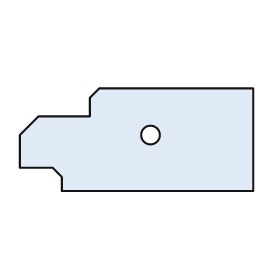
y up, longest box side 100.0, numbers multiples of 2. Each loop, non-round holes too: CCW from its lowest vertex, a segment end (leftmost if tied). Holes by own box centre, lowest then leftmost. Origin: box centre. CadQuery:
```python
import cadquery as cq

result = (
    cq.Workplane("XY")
    .moveTo(-32.0, -22.0)
    .lineTo(50.0, -22.0)
    .lineTo(50.0, 22.0)
    .lineTo(-16.0, 22.0)
    .lineTo(-20.0, 18.0)
    .lineTo(-20.0, 10.0)
    .lineTo(-42.0, 10.0)
    .lineTo(-50.0, 2.0)
    .lineTo(-50.0, -12.0)
    .lineTo(-36.0, -12.0)
    .lineTo(-32.0, -16.0)
    .close()
    .moveTo(6.0, 2.0)
    .circle(4.0)
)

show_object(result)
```